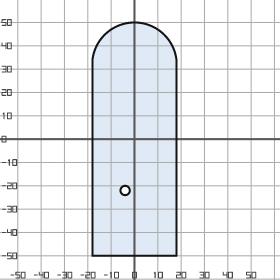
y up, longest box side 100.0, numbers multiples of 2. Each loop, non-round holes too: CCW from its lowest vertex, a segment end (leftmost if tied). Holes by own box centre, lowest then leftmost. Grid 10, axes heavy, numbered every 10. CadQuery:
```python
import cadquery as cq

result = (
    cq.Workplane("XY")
    .moveTo(-18.0, -50.0)
    .lineTo(18.0, -50.0)
    .lineTo(18.0, 34.0)
    .threePointArc((0.0, 50.0), (-18.0, 34.0))
    .close()
    .moveTo(-4.0, -22.0)
    .circle(2.0)
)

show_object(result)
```